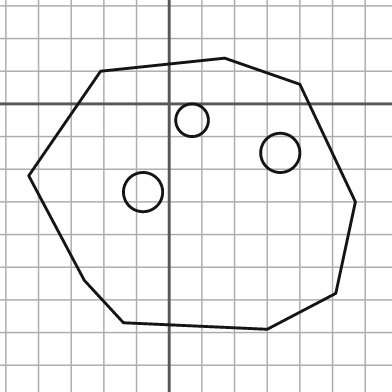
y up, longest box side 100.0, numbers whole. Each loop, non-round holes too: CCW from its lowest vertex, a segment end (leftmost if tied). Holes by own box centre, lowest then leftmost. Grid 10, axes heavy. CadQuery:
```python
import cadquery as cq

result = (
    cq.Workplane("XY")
    .moveTo(30.0, -69.0)
    .lineTo(51.0, -58.0)
    .lineTo(57.0, -30.0)
    .lineTo(40.0, 6.0)
    .lineTo(17.0, 14.0)
    .lineTo(-21.0, 10.0)
    .lineTo(-43.0, -22.0)
    .lineTo(-26.0, -54.0)
    .lineTo(-14.0, -67.0)
    .close()
    .moveTo(-8.0, -27.0)
    .circle(6.0)
    .moveTo(34.0, -15.0)
    .circle(6.0)
    .moveTo(7.0, -5.0)
    .circle(5.0)
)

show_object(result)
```